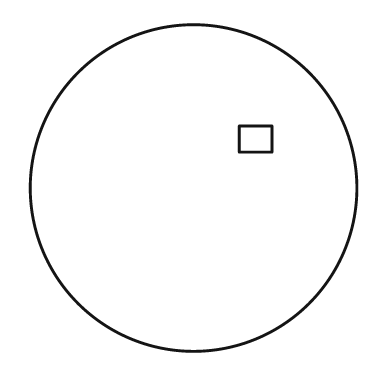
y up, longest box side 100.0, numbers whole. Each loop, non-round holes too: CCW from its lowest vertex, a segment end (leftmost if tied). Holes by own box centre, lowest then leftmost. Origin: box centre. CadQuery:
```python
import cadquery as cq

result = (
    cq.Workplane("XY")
    .moveTo(0.0, 0.0)
    .circle(50.0)
    .moveTo(14.0, 11.0)
    .lineTo(24.0, 11.0)
    .lineTo(24.0, 19.0)
    .lineTo(14.0, 19.0)
    .close()
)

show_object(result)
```